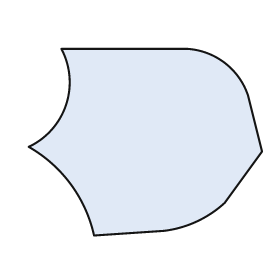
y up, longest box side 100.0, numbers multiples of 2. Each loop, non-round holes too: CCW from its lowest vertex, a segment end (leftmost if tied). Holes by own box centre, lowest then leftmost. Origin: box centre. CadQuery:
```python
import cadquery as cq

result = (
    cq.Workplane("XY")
    .moveTo(-22.0, -40.0)
    .lineTo(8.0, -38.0)
    .threePointArc((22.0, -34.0), (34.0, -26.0))
    .lineTo(50.0, -4.0)
    .lineTo(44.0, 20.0)
    .threePointArc((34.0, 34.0), (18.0, 40.0))
    .lineTo(-36.0, 40.0)
    .threePointArc((-34.0, 16.0), (-50.0, -2.0))
    .threePointArc((-32.0, -18.0), (-22.0, -40.0))
    .close()
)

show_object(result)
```